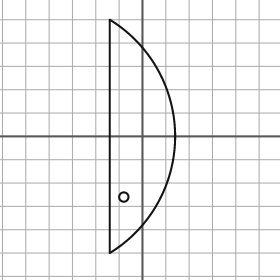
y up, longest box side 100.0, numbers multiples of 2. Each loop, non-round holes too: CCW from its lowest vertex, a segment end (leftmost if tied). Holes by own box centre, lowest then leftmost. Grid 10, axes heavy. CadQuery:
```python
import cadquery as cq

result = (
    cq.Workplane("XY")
    .moveTo(-14.0, -50.0)
    .threePointArc((14.0, 0.0), (-14.0, 50.0))
    .close()
    .moveTo(-8.0, -26.0)
    .circle(2.0)
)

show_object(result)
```